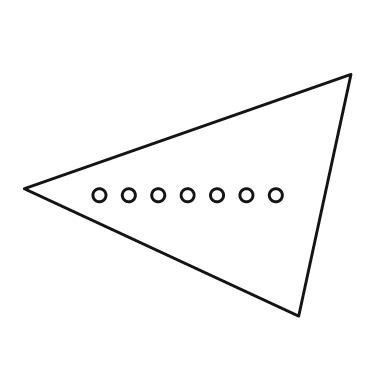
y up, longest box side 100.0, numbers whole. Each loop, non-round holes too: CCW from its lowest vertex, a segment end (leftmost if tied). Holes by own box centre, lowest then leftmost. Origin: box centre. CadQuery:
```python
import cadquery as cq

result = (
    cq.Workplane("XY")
    .moveTo(34.0, -37.0)
    .lineTo(50.0, 37.0)
    .lineTo(-50.0, 2.0)
    .close()
    .moveTo(-27.0, 0.0)
    .circle(2.0)
    .moveTo(-18.0, 0.0)
    .circle(2.0)
    .moveTo(-9.0, 0.0)
    .circle(2.0)
    .moveTo(0.0, 0.0)
    .circle(2.0)
    .moveTo(9.0, 0.0)
    .circle(2.0)
    .moveTo(18.0, 0.0)
    .circle(2.0)
    .moveTo(27.0, 0.0)
    .circle(2.0)
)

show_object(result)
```